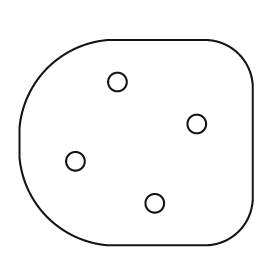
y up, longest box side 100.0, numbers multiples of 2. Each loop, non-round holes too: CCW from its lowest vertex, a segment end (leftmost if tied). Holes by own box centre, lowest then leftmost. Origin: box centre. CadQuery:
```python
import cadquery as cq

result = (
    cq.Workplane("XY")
    .moveTo(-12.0, -44.0)
    .lineTo(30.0, -44.0)
    .threePointArc((44.0, -38.0), (50.0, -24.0))
    .lineTo(50.0, 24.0)
    .threePointArc((44.0, 38.0), (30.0, 44.0))
    .lineTo(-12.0, 44.0)
    .threePointArc((-38.0, 32.0), (-50.0, 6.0))
    .lineTo(-50.0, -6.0)
    .threePointArc((-38.0, -32.0), (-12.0, -44.0))
    .close()
    .moveTo(8.0, -26.0)
    .circle(4.0)
    .moveTo(-26.0, -8.0)
    .circle(4.0)
    .moveTo(26.0, 8.0)
    .circle(4.0)
    .moveTo(-8.0, 26.0)
    .circle(4.0)
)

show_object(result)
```